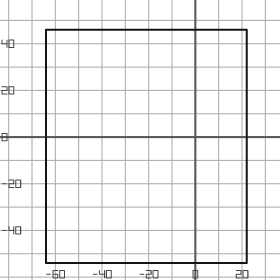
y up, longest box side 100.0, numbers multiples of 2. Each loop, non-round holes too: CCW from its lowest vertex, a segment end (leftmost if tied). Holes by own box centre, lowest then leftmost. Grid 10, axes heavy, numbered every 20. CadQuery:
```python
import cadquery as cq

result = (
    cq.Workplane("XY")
    .moveTo(-64.0, -54.0)
    .lineTo(22.0, -54.0)
    .lineTo(22.0, 46.0)
    .lineTo(-64.0, 46.0)
    .close()
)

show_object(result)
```